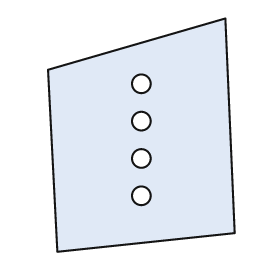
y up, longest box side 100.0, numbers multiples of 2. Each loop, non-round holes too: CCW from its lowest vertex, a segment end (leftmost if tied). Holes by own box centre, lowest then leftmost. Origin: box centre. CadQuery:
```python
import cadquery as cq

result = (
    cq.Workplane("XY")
    .moveTo(-36.0, -50.0)
    .lineTo(40.0, -42.0)
    .lineTo(36.0, 50.0)
    .lineTo(-40.0, 28.0)
    .close()
    .moveTo(0.0, -26.0)
    .circle(4.0)
    .moveTo(0.0, -10.0)
    .circle(4.0)
    .moveTo(0.0, 6.0)
    .circle(4.0)
    .moveTo(0.0, 22.0)
    .circle(4.0)
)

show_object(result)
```